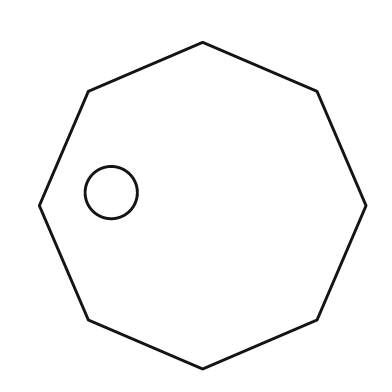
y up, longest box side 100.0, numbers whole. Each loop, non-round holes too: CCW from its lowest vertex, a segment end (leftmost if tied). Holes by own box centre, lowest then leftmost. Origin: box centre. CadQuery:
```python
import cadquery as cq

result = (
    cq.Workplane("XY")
    .moveTo(0.0, -50.0)
    .lineTo(35.0, -35.0)
    .lineTo(50.0, 0.0)
    .lineTo(35.0, 35.0)
    .lineTo(0.0, 50.0)
    .lineTo(-35.0, 35.0)
    .lineTo(-50.0, 0.0)
    .lineTo(-35.0, -35.0)
    .close()
    .moveTo(-28.0, 4.0)
    .circle(8.0)
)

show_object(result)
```